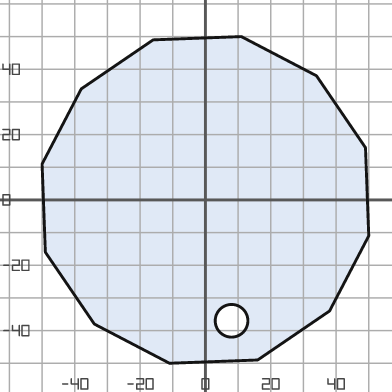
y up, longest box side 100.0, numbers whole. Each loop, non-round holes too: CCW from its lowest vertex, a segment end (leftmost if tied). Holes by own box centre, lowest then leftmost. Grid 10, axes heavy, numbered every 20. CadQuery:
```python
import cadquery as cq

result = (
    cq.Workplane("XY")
    .moveTo(-11.0, -50.0)
    .lineTo(16.0, -49.0)
    .lineTo(38.0, -34.0)
    .lineTo(50.0, -11.0)
    .lineTo(49.0, 16.0)
    .lineTo(34.0, 38.0)
    .lineTo(11.0, 50.0)
    .lineTo(-16.0, 49.0)
    .lineTo(-38.0, 34.0)
    .lineTo(-50.0, 11.0)
    .lineTo(-49.0, -16.0)
    .lineTo(-34.0, -38.0)
    .close()
    .moveTo(8.0, -37.0)
    .circle(5.0)
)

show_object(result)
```